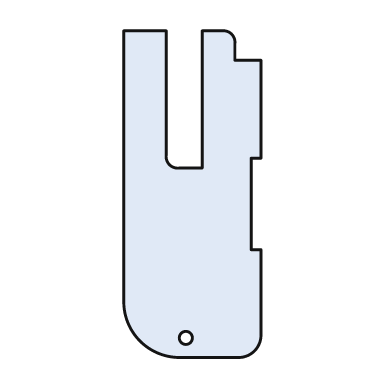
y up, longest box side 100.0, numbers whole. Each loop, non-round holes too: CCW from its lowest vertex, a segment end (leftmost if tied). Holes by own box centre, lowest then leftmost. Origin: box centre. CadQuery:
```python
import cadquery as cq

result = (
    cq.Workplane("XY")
    .moveTo(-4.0, -50.0)
    .lineTo(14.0, -50.0)
    .threePointArc((19.0, -48.0), (21.0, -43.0))
    .lineTo(21.0, -17.0)
    .lineTo(18.0, -17.0)
    .lineTo(18.0, 11.0)
    .lineTo(21.0, 11.0)
    .lineTo(21.0, 41.0)
    .lineTo(13.0, 41.0)
    .lineTo(13.0, 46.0)
    .threePointArc((12.0, 49.0), (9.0, 50.0))
    .lineTo(3.0, 50.0)
    .lineTo(3.0, 8.0)
    .lineTo(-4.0, 8.0)
    .threePointArc((-7.0, 9.0), (-8.0, 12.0))
    .lineTo(-8.0, 50.0)
    .lineTo(-21.0, 50.0)
    .lineTo(-21.0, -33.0)
    .threePointArc((-16.0, -45.0), (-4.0, -50.0))
    .close()
    .moveTo(-2.0, -44.0)
    .circle(2.0)
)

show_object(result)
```